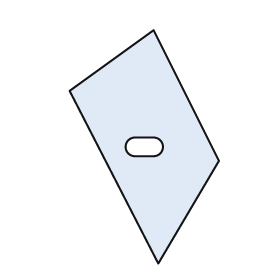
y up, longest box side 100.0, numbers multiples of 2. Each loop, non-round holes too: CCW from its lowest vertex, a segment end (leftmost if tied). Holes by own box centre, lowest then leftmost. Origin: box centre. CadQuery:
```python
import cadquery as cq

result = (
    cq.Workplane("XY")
    .moveTo(6.0, -50.0)
    .lineTo(32.0, -6.0)
    .lineTo(4.0, 50.0)
    .lineTo(-32.0, 24.0)
    .close()
    .moveTo(-4.0, -4.0)
    .lineTo(4.0, -4.0)
    .threePointArc((8.0, 0.0), (4.0, 4.0))
    .lineTo(-4.0, 4.0)
    .threePointArc((-8.0, 0.0), (-4.0, -4.0))
    .close()
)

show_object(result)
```